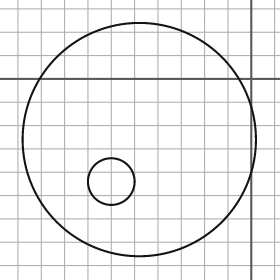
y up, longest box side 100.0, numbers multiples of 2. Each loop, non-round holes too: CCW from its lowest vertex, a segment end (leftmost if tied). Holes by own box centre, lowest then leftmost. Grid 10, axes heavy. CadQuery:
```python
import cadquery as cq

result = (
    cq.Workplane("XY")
    .moveTo(-48.0, -26.0)
    .circle(50.0)
    .moveTo(-60.0, -44.0)
    .circle(10.0)
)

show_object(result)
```